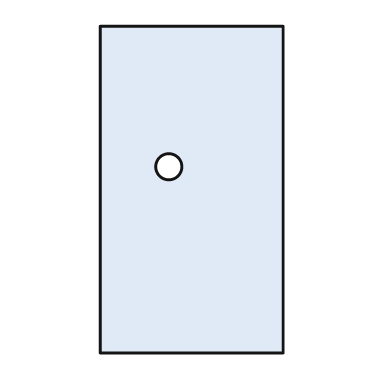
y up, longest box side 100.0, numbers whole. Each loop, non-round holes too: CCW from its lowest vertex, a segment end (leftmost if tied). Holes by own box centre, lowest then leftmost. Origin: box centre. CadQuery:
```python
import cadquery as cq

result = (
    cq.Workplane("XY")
    .moveTo(-28.0, -50.0)
    .lineTo(28.0, -50.0)
    .lineTo(28.0, 50.0)
    .lineTo(-28.0, 50.0)
    .close()
    .moveTo(-7.0, 7.0)
    .circle(4.0)
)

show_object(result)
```